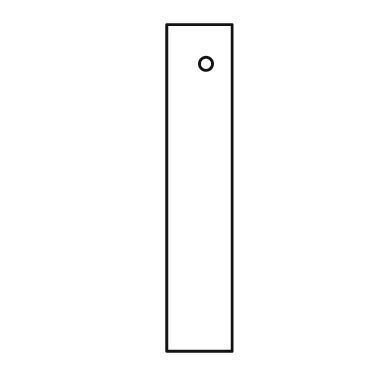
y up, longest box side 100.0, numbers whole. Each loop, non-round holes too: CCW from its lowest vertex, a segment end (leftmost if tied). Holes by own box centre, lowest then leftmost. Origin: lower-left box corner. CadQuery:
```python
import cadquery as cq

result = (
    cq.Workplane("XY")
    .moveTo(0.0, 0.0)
    .lineTo(20.0, 0.0)
    .lineTo(20.0, 100.0)
    .lineTo(0.0, 100.0)
    .close()
    .moveTo(12.0, 88.0)
    .circle(2.0)
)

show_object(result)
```